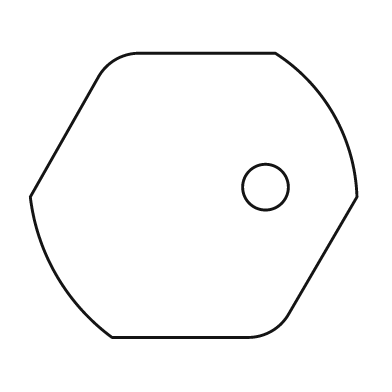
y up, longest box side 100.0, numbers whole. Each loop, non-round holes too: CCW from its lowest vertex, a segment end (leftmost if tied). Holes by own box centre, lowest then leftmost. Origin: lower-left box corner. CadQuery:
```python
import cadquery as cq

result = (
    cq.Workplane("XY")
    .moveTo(25.0, 0.0)
    .lineTo(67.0, 0.0)
    .threePointArc((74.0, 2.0), (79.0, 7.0))
    .lineTo(100.0, 43.0)
    .threePointArc((93.0, 68.0), (75.0, 87.0))
    .lineTo(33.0, 87.0)
    .threePointArc((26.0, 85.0), (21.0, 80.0))
    .lineTo(0.0, 43.0)
    .threePointArc((8.0, 19.0), (25.0, 0.0))
    .close()
    .moveTo(72.0, 46.0)
    .circle(7.0)
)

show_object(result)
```